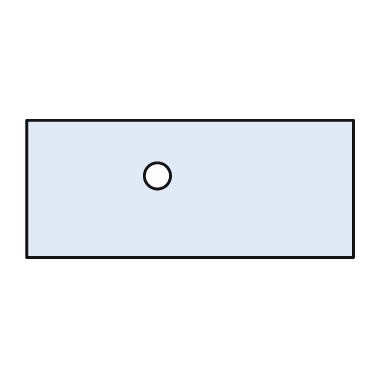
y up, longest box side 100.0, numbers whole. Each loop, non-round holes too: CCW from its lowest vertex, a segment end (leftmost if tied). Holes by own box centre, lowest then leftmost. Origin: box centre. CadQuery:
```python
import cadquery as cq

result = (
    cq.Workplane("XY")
    .moveTo(-50.0, -21.0)
    .lineTo(50.0, -21.0)
    .lineTo(50.0, 21.0)
    .lineTo(-50.0, 21.0)
    .close()
    .moveTo(-10.0, 4.0)
    .circle(4.0)
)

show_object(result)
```